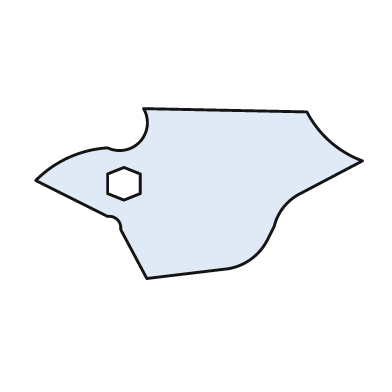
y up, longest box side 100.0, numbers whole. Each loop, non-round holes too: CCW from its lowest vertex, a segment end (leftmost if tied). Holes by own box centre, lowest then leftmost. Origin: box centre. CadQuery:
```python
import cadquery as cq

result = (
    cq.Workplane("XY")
    .moveTo(-16.0, -26.0)
    .lineTo(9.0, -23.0)
    .threePointArc((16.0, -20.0), (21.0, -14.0))
    .lineTo(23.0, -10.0)
    .threePointArc((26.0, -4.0), (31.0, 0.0))
    .lineTo(50.0, 10.0)
    .threePointArc((40.0, 16.0), (33.0, 25.0))
    .lineTo(-17.0, 26.0)
    .threePointArc((-18.0, 16.0), (-28.0, 14.0))
    .threePointArc((-40.0, 11.0), (-50.0, 4.0))
    .lineTo(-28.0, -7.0)
    .threePointArc((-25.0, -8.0), (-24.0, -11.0))
    .close()
    .moveTo(-23.0, -2.0)
    .lineTo(-18.0, 0.0)
    .lineTo(-18.0, 6.0)
    .lineTo(-23.0, 8.0)
    .lineTo(-28.0, 6.0)
    .lineTo(-28.0, 0.0)
    .close()
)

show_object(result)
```